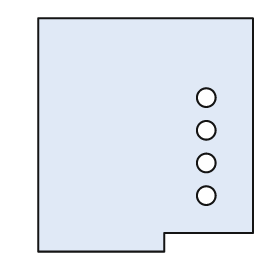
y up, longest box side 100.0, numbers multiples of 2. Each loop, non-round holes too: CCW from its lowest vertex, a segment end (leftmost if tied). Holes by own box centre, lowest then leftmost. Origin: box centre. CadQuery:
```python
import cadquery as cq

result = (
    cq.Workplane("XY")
    .moveTo(-46.0, -50.0)
    .lineTo(8.0, -50.0)
    .lineTo(8.0, -42.0)
    .lineTo(46.0, -42.0)
    .lineTo(46.0, 50.0)
    .lineTo(-46.0, 50.0)
    .close()
    .moveTo(26.0, -26.0)
    .circle(4.0)
    .moveTo(26.0, -12.0)
    .circle(4.0)
    .moveTo(26.0, 2.0)
    .circle(4.0)
    .moveTo(26.0, 16.0)
    .circle(4.0)
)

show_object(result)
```